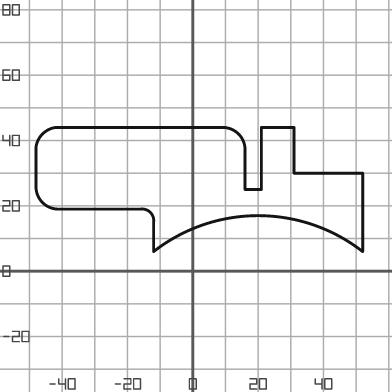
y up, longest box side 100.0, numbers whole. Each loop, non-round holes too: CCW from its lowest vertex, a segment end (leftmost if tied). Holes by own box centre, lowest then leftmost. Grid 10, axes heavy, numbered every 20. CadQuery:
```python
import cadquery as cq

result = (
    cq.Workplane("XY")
    .moveTo(-12.0, 6.0)
    .threePointArc((20.0, 17.0), (52.0, 6.0))
    .lineTo(52.0, 30.0)
    .lineTo(31.0, 30.0)
    .lineTo(31.0, 44.0)
    .lineTo(21.0, 44.0)
    .lineTo(21.0, 25.0)
    .lineTo(16.0, 25.0)
    .lineTo(16.0, 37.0)
    .threePointArc((14.0, 42.0), (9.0, 44.0))
    .lineTo(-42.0, 44.0)
    .threePointArc((-46.0, 42.0), (-48.0, 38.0))
    .lineTo(-48.0, 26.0)
    .threePointArc((-46.0, 21.0), (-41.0, 19.0))
    .lineTo(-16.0, 19.0)
    .threePointArc((-13.0, 18.0), (-12.0, 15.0))
    .close()
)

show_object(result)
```